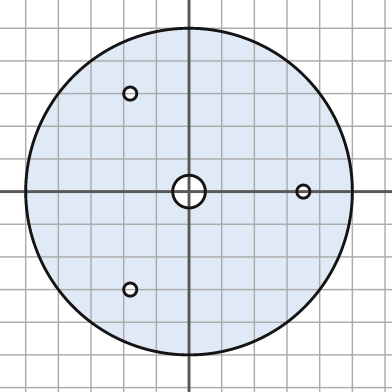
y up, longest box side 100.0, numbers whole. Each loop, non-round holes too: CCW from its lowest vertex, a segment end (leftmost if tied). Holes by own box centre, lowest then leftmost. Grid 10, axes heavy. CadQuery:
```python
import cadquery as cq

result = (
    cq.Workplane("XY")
    .moveTo(0.0, 0.0)
    .circle(50.0)
    .moveTo(-18.0, -30.0)
    .circle(2.0)
    .moveTo(0.0, 0.0)
    .circle(5.0)
    .moveTo(35.0, 0.0)
    .circle(2.0)
    .moveTo(-18.0, 30.0)
    .circle(2.0)
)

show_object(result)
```